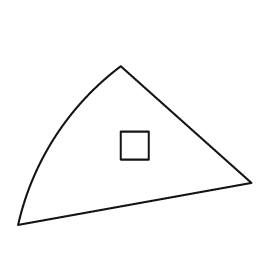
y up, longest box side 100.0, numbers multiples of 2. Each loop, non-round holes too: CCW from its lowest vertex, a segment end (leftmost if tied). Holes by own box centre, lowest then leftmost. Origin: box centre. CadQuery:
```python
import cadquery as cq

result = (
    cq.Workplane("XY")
    .moveTo(-50.0, -34.0)
    .lineTo(50.0, -16.0)
    .lineTo(-6.0, 34.0)
    .threePointArc((-34.0, 4.0), (-50.0, -34.0))
    .close()
    .moveTo(-6.0, -6.0)
    .lineTo(6.0, -6.0)
    .lineTo(6.0, 6.0)
    .lineTo(-6.0, 6.0)
    .close()
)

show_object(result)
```